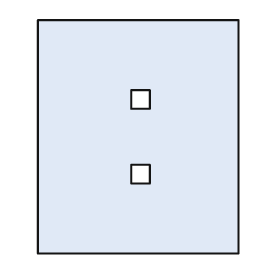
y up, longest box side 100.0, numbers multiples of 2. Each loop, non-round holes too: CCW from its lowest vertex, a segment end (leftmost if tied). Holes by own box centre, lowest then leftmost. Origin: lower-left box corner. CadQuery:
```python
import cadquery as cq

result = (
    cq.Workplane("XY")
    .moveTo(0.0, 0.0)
    .lineTo(86.0, 0.0)
    .lineTo(86.0, 100.0)
    .lineTo(0.0, 100.0)
    .close()
    .moveTo(40.0, 30.0)
    .lineTo(48.0, 30.0)
    .lineTo(48.0, 38.0)
    .lineTo(40.0, 38.0)
    .close()
    .moveTo(40.0, 62.0)
    .lineTo(48.0, 62.0)
    .lineTo(48.0, 70.0)
    .lineTo(40.0, 70.0)
    .close()
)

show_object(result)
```